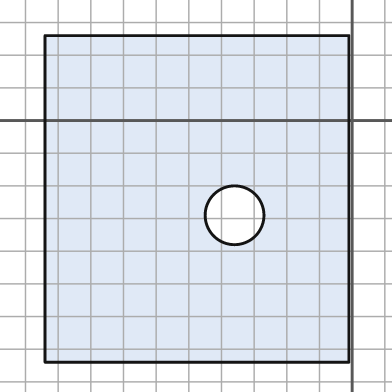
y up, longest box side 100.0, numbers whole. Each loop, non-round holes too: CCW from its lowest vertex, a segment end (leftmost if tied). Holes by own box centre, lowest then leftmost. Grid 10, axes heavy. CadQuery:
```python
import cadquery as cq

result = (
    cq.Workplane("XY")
    .moveTo(-94.0, -74.0)
    .lineTo(-1.0, -74.0)
    .lineTo(-1.0, 26.0)
    .lineTo(-94.0, 26.0)
    .close()
    .moveTo(-36.0, -29.0)
    .circle(9.0)
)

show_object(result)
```